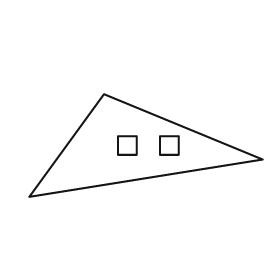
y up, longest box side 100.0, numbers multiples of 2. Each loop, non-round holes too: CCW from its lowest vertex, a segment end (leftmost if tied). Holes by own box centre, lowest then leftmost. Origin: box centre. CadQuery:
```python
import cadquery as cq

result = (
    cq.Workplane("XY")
    .moveTo(-50.0, -22.0)
    .lineTo(50.0, -6.0)
    .lineTo(-18.0, 22.0)
    .close()
    .moveTo(-12.0, -4.0)
    .lineTo(-4.0, -4.0)
    .lineTo(-4.0, 4.0)
    .lineTo(-12.0, 4.0)
    .close()
    .moveTo(6.0, -4.0)
    .lineTo(14.0, -4.0)
    .lineTo(14.0, 4.0)
    .lineTo(6.0, 4.0)
    .close()
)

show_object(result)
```